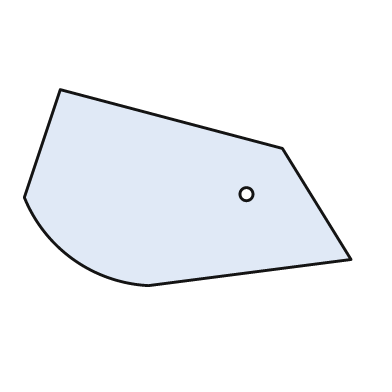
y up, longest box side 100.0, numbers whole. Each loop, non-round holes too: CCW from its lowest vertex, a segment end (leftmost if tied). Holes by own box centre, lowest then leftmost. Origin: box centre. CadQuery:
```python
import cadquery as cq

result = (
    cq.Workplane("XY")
    .moveTo(-12.0, -30.0)
    .lineTo(50.0, -22.0)
    .lineTo(29.0, 12.0)
    .lineTo(-39.0, 30.0)
    .lineTo(-50.0, -3.0)
    .threePointArc((-35.0, -22.0), (-12.0, -30.0))
    .close()
    .moveTo(18.0, -2.0)
    .circle(2.0)
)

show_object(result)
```